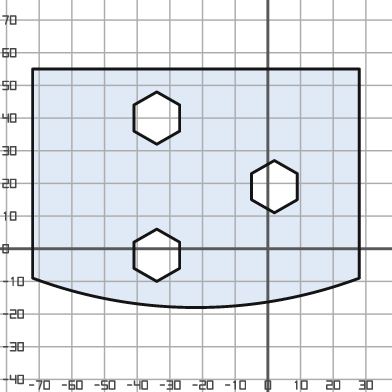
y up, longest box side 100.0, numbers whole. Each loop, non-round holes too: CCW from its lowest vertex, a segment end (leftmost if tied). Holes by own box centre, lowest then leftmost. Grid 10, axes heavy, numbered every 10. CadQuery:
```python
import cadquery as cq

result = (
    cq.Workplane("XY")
    .moveTo(-72.0, -9.0)
    .threePointArc((-22.0, -18.0), (28.0, -9.0))
    .lineTo(28.0, 55.0)
    .lineTo(-72.0, 55.0)
    .close()
    .moveTo(-34.0, -10.0)
    .lineTo(-27.0, -6.0)
    .lineTo(-27.0, 2.0)
    .lineTo(-34.0, 6.0)
    .lineTo(-41.0, 2.0)
    .lineTo(-41.0, -6.0)
    .close()
    .moveTo(2.0, 11.0)
    .lineTo(9.0, 15.0)
    .lineTo(9.0, 23.0)
    .lineTo(2.0, 27.0)
    .lineTo(-5.0, 23.0)
    .lineTo(-5.0, 15.0)
    .close()
    .moveTo(-34.0, 32.0)
    .lineTo(-27.0, 36.0)
    .lineTo(-27.0, 44.0)
    .lineTo(-34.0, 48.0)
    .lineTo(-41.0, 44.0)
    .lineTo(-41.0, 36.0)
    .close()
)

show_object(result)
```